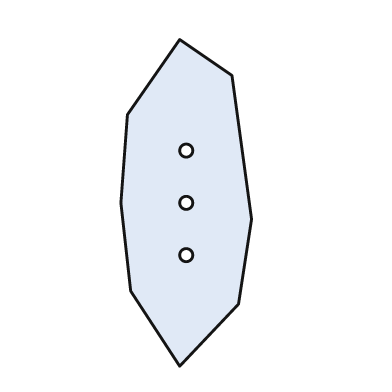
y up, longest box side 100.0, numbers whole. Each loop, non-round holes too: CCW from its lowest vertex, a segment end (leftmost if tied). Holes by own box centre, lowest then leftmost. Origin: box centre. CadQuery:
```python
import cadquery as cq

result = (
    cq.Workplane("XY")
    .moveTo(-2.0, -50.0)
    .lineTo(16.0, -31.0)
    .lineTo(20.0, -5.0)
    .lineTo(14.0, 39.0)
    .lineTo(-2.0, 50.0)
    .lineTo(-18.0, 27.0)
    .lineTo(-20.0, 0.0)
    .lineTo(-17.0, -27.0)
    .close()
    .moveTo(0.0, -16.0)
    .circle(2.0)
    .moveTo(0.0, 0.0)
    .circle(2.0)
    .moveTo(0.0, 16.0)
    .circle(2.0)
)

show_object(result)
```